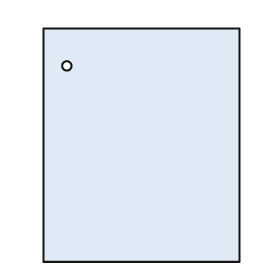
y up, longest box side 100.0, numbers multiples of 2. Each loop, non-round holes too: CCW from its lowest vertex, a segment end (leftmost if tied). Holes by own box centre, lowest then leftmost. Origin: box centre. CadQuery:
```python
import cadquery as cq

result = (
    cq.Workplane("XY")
    .moveTo(-42.0, -50.0)
    .lineTo(42.0, -50.0)
    .lineTo(42.0, 50.0)
    .lineTo(-42.0, 50.0)
    .close()
    .moveTo(-32.0, 34.0)
    .circle(2.0)
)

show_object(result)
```